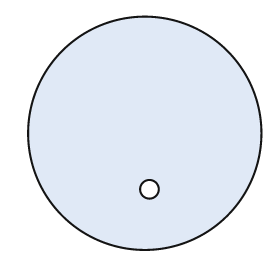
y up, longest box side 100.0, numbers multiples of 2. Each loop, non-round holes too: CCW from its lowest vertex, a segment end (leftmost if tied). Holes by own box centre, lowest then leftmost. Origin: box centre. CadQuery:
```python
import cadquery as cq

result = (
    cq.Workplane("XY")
    .moveTo(0.0, 0.0)
    .circle(50.0)
    .moveTo(2.0, -24.0)
    .circle(4.0)
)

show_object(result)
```